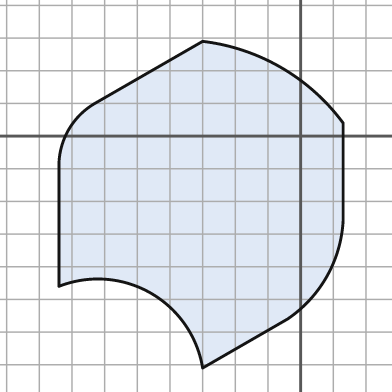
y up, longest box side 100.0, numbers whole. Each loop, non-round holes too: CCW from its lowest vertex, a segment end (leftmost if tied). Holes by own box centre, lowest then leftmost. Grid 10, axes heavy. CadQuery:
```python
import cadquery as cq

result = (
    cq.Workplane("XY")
    .moveTo(-30.0, -71.0)
    .lineTo(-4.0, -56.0)
    .threePointArc((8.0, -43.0), (13.0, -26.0))
    .lineTo(13.0, 4.0)
    .threePointArc((-6.0, 21.0), (-30.0, 29.0))
    .lineTo(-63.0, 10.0)
    .threePointArc((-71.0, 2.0), (-74.0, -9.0))
    .lineTo(-74.0, -46.0)
    .threePointArc((-46.0, -48.0), (-30.0, -71.0))
    .close()
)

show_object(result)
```